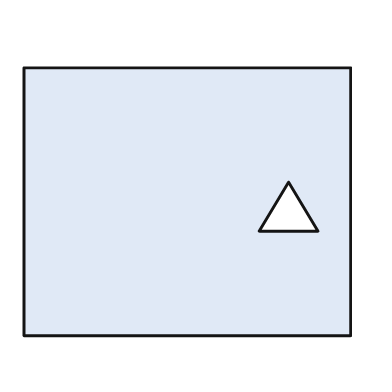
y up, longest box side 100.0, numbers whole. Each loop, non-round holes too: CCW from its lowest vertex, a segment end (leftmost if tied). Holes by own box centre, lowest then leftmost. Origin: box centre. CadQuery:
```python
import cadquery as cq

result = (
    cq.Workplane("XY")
    .moveTo(-50.0, -41.0)
    .lineTo(50.0, -41.0)
    .lineTo(50.0, 41.0)
    .lineTo(-50.0, 41.0)
    .close()
    .moveTo(22.0, -9.0)
    .lineTo(40.0, -9.0)
    .lineTo(31.0, 6.0)
    .close()
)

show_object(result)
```